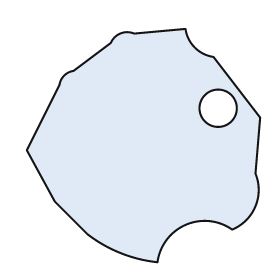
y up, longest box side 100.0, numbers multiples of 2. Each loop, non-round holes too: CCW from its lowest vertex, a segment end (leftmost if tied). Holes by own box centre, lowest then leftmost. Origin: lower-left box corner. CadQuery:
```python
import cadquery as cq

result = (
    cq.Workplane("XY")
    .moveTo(56.0, 0.0)
    .threePointArc((68.0, 16.0), (88.0, 14.0))
    .threePointArc((98.0, 24.0), (98.0, 38.0))
    .lineTo(100.0, 62.0)
    .lineTo(80.0, 88.0)
    .threePointArc((72.0, 92.0), (68.0, 100.0))
    .lineTo(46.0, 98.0)
    .threePointArc((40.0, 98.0), (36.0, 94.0))
    .lineTo(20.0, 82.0)
    .threePointArc((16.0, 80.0), (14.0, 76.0))
    .lineTo(0.0, 48.0)
    .lineTo(12.0, 26.0)
    .lineTo(26.0, 12.0)
    .threePointArc((40.0, 4.0), (56.0, 0.0))
    .close()
    .moveTo(82.0, 66.0)
    .circle(8.0)
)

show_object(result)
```